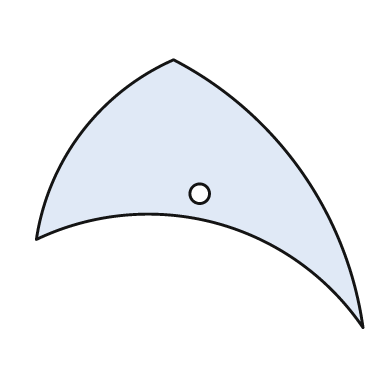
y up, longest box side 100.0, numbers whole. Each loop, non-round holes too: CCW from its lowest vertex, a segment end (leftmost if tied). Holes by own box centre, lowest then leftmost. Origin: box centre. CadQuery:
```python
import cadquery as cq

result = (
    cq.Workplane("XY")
    .moveTo(50.0, -41.0)
    .threePointArc((31.0, 7.0), (-8.0, 41.0))
    .threePointArc((-36.0, 19.0), (-50.0, -14.0))
    .threePointArc((5.0, -9.0), (50.0, -41.0))
    .close()
    .moveTo(0.0, 0.0)
    .circle(3.0)
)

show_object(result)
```